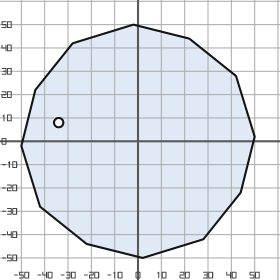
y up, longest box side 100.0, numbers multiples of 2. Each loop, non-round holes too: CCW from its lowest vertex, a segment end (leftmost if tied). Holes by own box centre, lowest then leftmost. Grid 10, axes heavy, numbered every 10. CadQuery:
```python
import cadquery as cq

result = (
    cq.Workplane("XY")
    .moveTo(2.0, -50.0)
    .lineTo(28.0, -42.0)
    .lineTo(44.0, -22.0)
    .lineTo(50.0, 2.0)
    .lineTo(42.0, 28.0)
    .lineTo(22.0, 44.0)
    .lineTo(-2.0, 50.0)
    .lineTo(-28.0, 42.0)
    .lineTo(-44.0, 22.0)
    .lineTo(-50.0, -2.0)
    .lineTo(-42.0, -28.0)
    .lineTo(-22.0, -44.0)
    .close()
    .moveTo(-34.0, 8.0)
    .circle(2.0)
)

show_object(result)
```